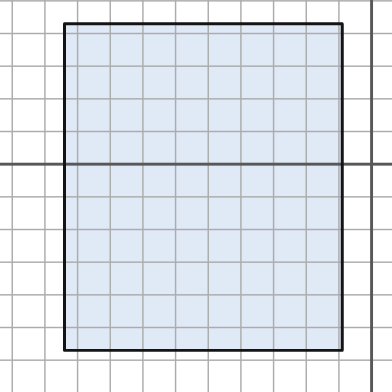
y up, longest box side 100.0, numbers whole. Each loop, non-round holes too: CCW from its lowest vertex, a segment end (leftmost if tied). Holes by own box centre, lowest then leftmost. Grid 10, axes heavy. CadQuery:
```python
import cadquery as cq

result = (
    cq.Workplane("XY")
    .moveTo(-94.0, -57.0)
    .lineTo(-9.0, -57.0)
    .lineTo(-9.0, 43.0)
    .lineTo(-94.0, 43.0)
    .close()
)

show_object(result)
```